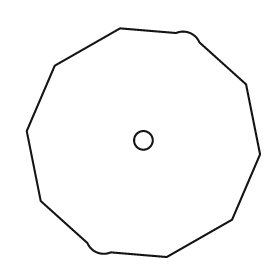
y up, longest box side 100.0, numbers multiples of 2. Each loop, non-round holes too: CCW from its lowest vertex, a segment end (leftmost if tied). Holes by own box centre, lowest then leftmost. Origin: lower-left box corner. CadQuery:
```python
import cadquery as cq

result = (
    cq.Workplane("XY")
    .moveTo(60.0, 0.0)
    .lineTo(88.0, 16.0)
    .lineTo(100.0, 44.0)
    .lineTo(94.0, 74.0)
    .lineTo(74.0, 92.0)
    .threePointArc((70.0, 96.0), (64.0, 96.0))
    .lineTo(40.0, 98.0)
    .lineTo(12.0, 82.0)
    .lineTo(0.0, 54.0)
    .lineTo(6.0, 24.0)
    .lineTo(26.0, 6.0)
    .threePointArc((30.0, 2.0), (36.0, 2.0))
    .close()
    .moveTo(50.0, 50.0)
    .circle(4.0)
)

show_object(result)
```